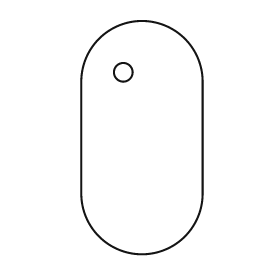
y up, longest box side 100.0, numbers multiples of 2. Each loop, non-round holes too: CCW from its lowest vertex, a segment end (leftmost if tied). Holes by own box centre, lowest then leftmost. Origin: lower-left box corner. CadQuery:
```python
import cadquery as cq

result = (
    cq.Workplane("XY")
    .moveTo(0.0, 26.0)
    .threePointArc((26.0, 0.0), (52.0, 26.0))
    .lineTo(52.0, 74.0)
    .threePointArc((26.0, 100.0), (0.0, 74.0))
    .close()
    .moveTo(18.0, 78.0)
    .circle(4.0)
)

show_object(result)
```